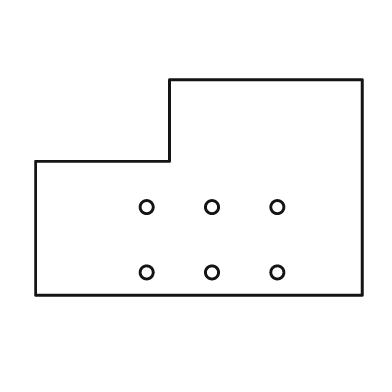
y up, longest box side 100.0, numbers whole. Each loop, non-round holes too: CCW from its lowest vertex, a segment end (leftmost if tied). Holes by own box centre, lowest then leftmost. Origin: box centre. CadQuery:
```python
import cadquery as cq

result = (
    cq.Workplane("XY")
    .moveTo(-50.0, -33.0)
    .lineTo(50.0, -33.0)
    .lineTo(50.0, 33.0)
    .lineTo(-9.0, 33.0)
    .lineTo(-9.0, 8.0)
    .lineTo(-50.0, 8.0)
    .close()
    .moveTo(-16.0, -26.0)
    .circle(2.0)
    .moveTo(4.0, -26.0)
    .circle(2.0)
    .moveTo(24.0, -26.0)
    .circle(2.0)
    .moveTo(-16.0, -6.0)
    .circle(2.0)
    .moveTo(4.0, -6.0)
    .circle(2.0)
    .moveTo(24.0, -6.0)
    .circle(2.0)
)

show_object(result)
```